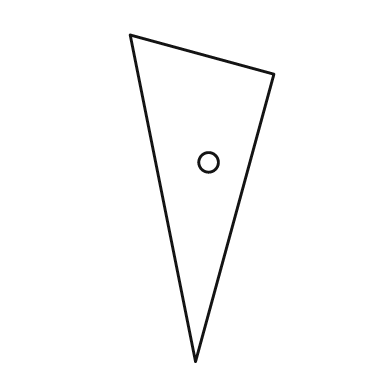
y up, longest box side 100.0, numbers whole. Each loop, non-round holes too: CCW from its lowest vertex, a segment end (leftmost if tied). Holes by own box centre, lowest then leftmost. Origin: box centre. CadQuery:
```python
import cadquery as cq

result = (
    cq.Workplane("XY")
    .moveTo(-2.0, -50.0)
    .lineTo(22.0, 38.0)
    .lineTo(-22.0, 50.0)
    .close()
    .moveTo(2.0, 11.0)
    .circle(3.0)
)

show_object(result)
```